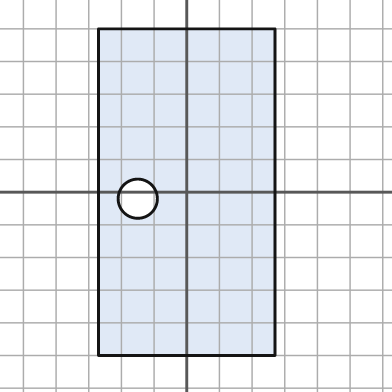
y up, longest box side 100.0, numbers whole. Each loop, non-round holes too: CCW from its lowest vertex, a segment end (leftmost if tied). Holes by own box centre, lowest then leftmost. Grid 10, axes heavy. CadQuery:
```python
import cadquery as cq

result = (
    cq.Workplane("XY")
    .moveTo(-27.0, -50.0)
    .lineTo(27.0, -50.0)
    .lineTo(27.0, 50.0)
    .lineTo(-27.0, 50.0)
    .close()
    .moveTo(-15.0, -2.0)
    .circle(6.0)
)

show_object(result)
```